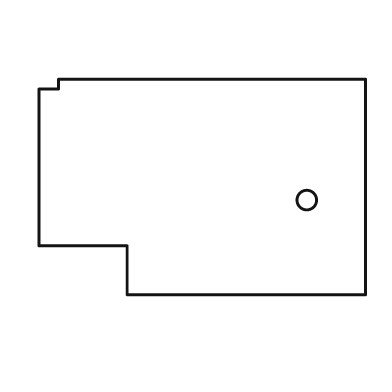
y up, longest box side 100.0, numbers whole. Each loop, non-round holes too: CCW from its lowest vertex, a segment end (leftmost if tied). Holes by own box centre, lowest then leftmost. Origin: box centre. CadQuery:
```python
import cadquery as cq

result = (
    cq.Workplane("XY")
    .moveTo(-23.0, -33.0)
    .lineTo(50.0, -33.0)
    .lineTo(50.0, 33.0)
    .lineTo(-44.0, 33.0)
    .lineTo(-44.0, 30.0)
    .lineTo(-50.0, 30.0)
    .lineTo(-50.0, -18.0)
    .lineTo(-23.0, -18.0)
    .close()
    .moveTo(32.0, -4.0)
    .circle(3.0)
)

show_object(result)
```